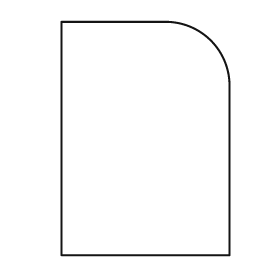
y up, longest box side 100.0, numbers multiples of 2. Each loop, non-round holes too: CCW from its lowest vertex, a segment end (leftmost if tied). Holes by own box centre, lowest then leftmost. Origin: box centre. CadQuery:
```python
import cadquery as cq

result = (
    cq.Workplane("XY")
    .moveTo(-36.0, -50.0)
    .lineTo(36.0, -50.0)
    .lineTo(36.0, 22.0)
    .threePointArc((28.0, 42.0), (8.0, 50.0))
    .lineTo(-36.0, 50.0)
    .close()
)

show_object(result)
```